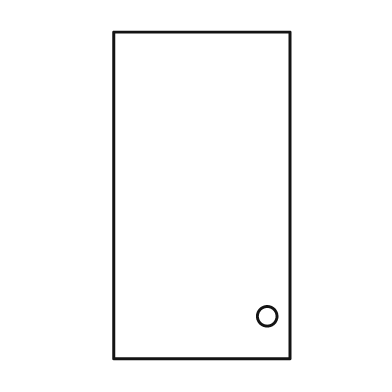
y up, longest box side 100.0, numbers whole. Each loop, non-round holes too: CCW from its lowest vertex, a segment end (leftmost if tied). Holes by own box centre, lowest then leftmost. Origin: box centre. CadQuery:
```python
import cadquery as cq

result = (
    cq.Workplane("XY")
    .moveTo(-27.0, -50.0)
    .lineTo(27.0, -50.0)
    .lineTo(27.0, 50.0)
    .lineTo(-27.0, 50.0)
    .close()
    .moveTo(20.0, -37.0)
    .circle(3.0)
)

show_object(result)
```